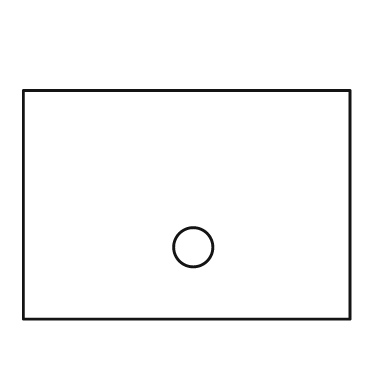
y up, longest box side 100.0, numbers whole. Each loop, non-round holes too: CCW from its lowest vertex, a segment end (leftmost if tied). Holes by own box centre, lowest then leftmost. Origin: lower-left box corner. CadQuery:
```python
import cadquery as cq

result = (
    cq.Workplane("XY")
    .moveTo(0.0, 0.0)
    .lineTo(100.0, 0.0)
    .lineTo(100.0, 70.0)
    .lineTo(0.0, 70.0)
    .close()
    .moveTo(52.0, 22.0)
    .circle(6.0)
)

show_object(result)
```